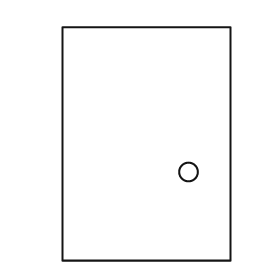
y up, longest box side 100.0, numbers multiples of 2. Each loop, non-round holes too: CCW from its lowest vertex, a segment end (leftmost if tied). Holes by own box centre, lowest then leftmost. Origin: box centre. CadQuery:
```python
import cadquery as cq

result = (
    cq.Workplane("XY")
    .moveTo(-36.0, -50.0)
    .lineTo(36.0, -50.0)
    .lineTo(36.0, 50.0)
    .lineTo(-36.0, 50.0)
    .close()
    .moveTo(18.0, -12.0)
    .circle(4.0)
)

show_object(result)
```